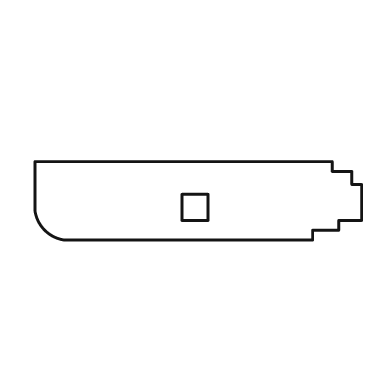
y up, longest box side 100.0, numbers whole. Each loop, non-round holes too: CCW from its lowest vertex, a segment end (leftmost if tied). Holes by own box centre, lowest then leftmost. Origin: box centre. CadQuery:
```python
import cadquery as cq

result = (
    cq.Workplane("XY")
    .moveTo(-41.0, -12.0)
    .lineTo(35.0, -12.0)
    .lineTo(35.0, -9.0)
    .lineTo(43.0, -9.0)
    .lineTo(43.0, -6.0)
    .lineTo(50.0, -6.0)
    .lineTo(50.0, 5.0)
    .lineTo(47.0, 5.0)
    .lineTo(47.0, 9.0)
    .lineTo(41.0, 9.0)
    .lineTo(41.0, 12.0)
    .lineTo(-50.0, 12.0)
    .lineTo(-50.0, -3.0)
    .threePointArc((-47.0, -9.0), (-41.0, -12.0))
    .close()
    .moveTo(-5.0, -6.0)
    .lineTo(3.0, -6.0)
    .lineTo(3.0, 2.0)
    .lineTo(-5.0, 2.0)
    .close()
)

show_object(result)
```